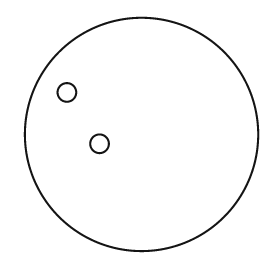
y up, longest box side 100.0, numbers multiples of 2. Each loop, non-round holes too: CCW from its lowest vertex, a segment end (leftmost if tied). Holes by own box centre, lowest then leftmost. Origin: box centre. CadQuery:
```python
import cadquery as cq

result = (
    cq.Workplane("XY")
    .moveTo(0.0, 0.0)
    .circle(50.0)
    .moveTo(-18.0, -4.0)
    .circle(4.0)
    .moveTo(-32.0, 18.0)
    .circle(4.0)
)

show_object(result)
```